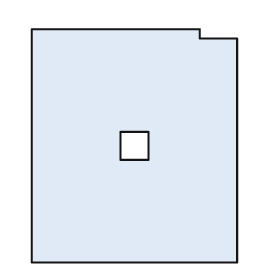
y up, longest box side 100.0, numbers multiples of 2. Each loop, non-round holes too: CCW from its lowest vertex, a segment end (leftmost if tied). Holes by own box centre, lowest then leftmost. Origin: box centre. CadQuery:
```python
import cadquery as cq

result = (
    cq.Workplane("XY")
    .moveTo(-44.0, -50.0)
    .lineTo(44.0, -50.0)
    .lineTo(44.0, 46.0)
    .lineTo(28.0, 46.0)
    .lineTo(28.0, 50.0)
    .lineTo(-44.0, 50.0)
    .close()
    .moveTo(-6.0, -6.0)
    .lineTo(6.0, -6.0)
    .lineTo(6.0, 6.0)
    .lineTo(-6.0, 6.0)
    .close()
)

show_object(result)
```